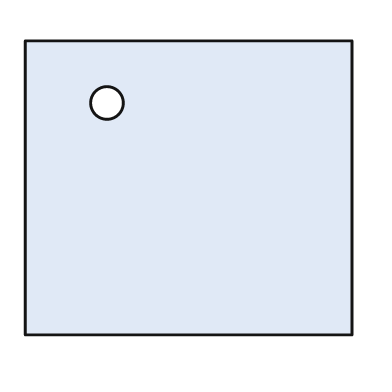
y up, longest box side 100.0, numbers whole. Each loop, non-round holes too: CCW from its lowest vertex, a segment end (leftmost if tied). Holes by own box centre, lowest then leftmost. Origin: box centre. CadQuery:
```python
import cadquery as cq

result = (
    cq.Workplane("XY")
    .moveTo(-50.0, -45.0)
    .lineTo(50.0, -45.0)
    .lineTo(50.0, 45.0)
    .lineTo(-50.0, 45.0)
    .close()
    .moveTo(-25.0, 26.0)
    .circle(5.0)
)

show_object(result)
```